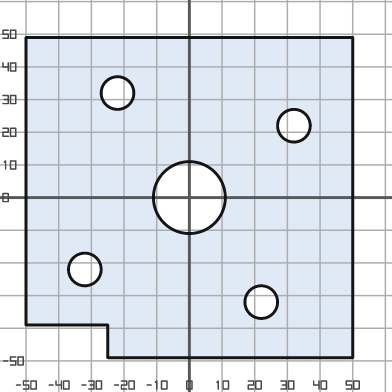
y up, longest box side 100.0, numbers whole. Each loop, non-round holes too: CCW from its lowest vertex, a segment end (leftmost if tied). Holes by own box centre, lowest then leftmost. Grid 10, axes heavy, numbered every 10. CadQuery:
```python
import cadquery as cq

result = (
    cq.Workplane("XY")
    .moveTo(-25.0, -49.0)
    .lineTo(50.0, -49.0)
    .lineTo(50.0, 49.0)
    .lineTo(-50.0, 49.0)
    .lineTo(-50.0, -39.0)
    .lineTo(-25.0, -39.0)
    .close()
    .moveTo(22.0, -32.0)
    .circle(5.0)
    .moveTo(-32.0, -22.0)
    .circle(5.0)
    .moveTo(0.0, 0.0)
    .circle(11.0)
    .moveTo(32.0, 22.0)
    .circle(5.0)
    .moveTo(-22.0, 32.0)
    .circle(5.0)
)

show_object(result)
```